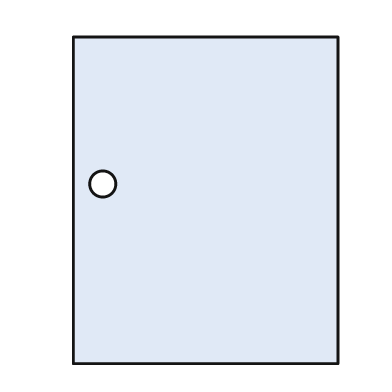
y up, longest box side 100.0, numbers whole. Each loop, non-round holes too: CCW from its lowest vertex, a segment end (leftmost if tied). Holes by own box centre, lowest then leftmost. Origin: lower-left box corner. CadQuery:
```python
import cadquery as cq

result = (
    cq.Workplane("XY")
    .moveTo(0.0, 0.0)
    .lineTo(81.0, 0.0)
    .lineTo(81.0, 100.0)
    .lineTo(0.0, 100.0)
    .close()
    .moveTo(9.0, 55.0)
    .circle(4.0)
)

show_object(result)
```